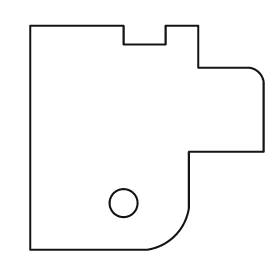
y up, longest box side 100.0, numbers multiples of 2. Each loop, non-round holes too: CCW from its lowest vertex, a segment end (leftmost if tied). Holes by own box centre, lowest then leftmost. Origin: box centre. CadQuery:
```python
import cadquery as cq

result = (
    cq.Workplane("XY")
    .moveTo(-50.0, -48.0)
    .lineTo(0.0, -48.0)
    .threePointArc((12.0, -42.0), (18.0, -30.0))
    .lineTo(18.0, -6.0)
    .lineTo(50.0, -6.0)
    .lineTo(50.0, 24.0)
    .threePointArc((48.0, 28.0), (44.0, 30.0))
    .lineTo(22.0, 30.0)
    .lineTo(22.0, 48.0)
    .lineTo(8.0, 48.0)
    .lineTo(8.0, 40.0)
    .lineTo(-10.0, 40.0)
    .lineTo(-10.0, 48.0)
    .lineTo(-50.0, 48.0)
    .close()
    .moveTo(-10.0, -28.0)
    .circle(6.0)
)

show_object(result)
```